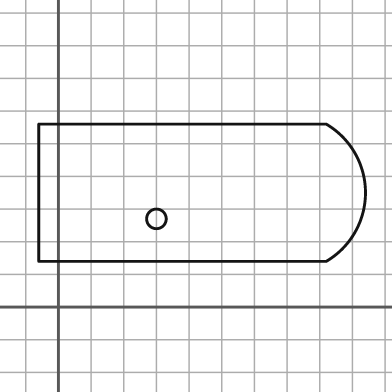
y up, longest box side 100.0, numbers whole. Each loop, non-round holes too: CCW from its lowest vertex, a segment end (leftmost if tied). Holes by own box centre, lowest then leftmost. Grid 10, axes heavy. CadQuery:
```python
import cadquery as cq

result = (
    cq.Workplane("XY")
    .moveTo(-6.0, 14.0)
    .lineTo(82.0, 14.0)
    .threePointArc((94.0, 35.0), (82.0, 56.0))
    .lineTo(-6.0, 56.0)
    .close()
    .moveTo(30.0, 27.0)
    .circle(3.0)
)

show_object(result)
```